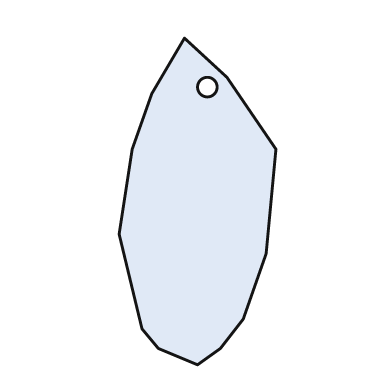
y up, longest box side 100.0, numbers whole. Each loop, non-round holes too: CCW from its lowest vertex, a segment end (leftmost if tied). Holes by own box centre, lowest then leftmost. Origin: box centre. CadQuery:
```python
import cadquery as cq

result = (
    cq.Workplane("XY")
    .moveTo(0.0, -50.0)
    .lineTo(7.0, -45.0)
    .lineTo(14.0, -36.0)
    .lineTo(21.0, -16.0)
    .lineTo(24.0, 16.0)
    .lineTo(9.0, 38.0)
    .lineTo(-4.0, 50.0)
    .lineTo(-14.0, 33.0)
    .lineTo(-20.0, 16.0)
    .lineTo(-24.0, -10.0)
    .lineTo(-17.0, -39.0)
    .lineTo(-12.0, -45.0)
    .close()
    .moveTo(3.0, 35.0)
    .circle(3.0)
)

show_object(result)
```